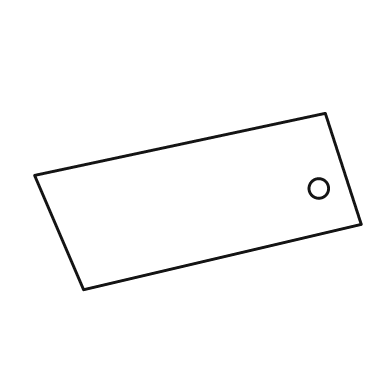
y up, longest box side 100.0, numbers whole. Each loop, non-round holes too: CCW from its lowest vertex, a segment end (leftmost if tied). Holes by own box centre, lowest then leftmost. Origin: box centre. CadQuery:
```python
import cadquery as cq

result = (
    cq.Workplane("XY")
    .moveTo(-35.0, -27.0)
    .lineTo(50.0, -7.0)
    .lineTo(39.0, 27.0)
    .lineTo(-50.0, 8.0)
    .close()
    .moveTo(37.0, 4.0)
    .circle(3.0)
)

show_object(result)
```